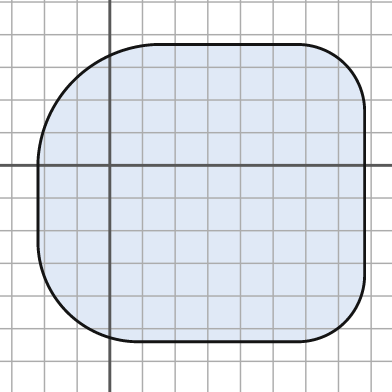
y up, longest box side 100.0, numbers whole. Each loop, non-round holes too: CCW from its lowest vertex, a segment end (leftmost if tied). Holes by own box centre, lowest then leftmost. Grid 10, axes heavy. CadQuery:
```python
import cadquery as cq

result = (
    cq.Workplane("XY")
    .moveTo(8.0, -54.0)
    .lineTo(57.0, -54.0)
    .threePointArc((72.0, -48.0), (78.0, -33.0))
    .lineTo(78.0, 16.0)
    .threePointArc((72.0, 31.0), (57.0, 37.0))
    .lineTo(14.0, 37.0)
    .threePointArc((-11.0, 26.0), (-22.0, 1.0))
    .lineTo(-22.0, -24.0)
    .threePointArc((-13.0, -45.0), (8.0, -54.0))
    .close()
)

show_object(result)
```